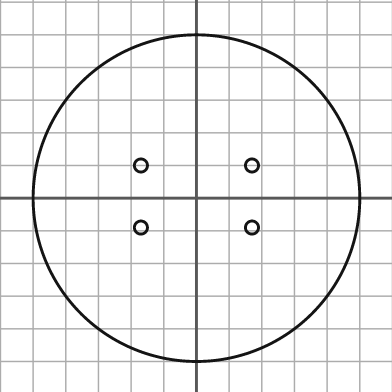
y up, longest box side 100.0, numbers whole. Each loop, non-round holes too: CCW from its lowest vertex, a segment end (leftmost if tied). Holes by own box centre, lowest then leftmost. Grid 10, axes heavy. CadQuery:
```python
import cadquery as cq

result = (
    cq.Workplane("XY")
    .moveTo(0.0, 0.0)
    .circle(50.0)
    .moveTo(-17.0, -9.0)
    .circle(2.0)
    .moveTo(17.0, -9.0)
    .circle(2.0)
    .moveTo(-17.0, 10.0)
    .circle(2.0)
    .moveTo(17.0, 10.0)
    .circle(2.0)
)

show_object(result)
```